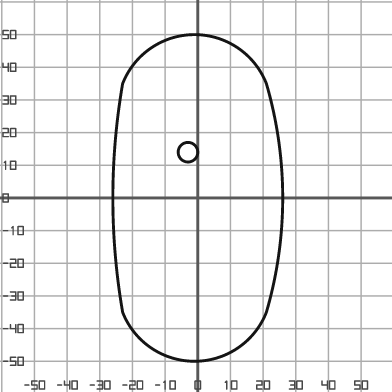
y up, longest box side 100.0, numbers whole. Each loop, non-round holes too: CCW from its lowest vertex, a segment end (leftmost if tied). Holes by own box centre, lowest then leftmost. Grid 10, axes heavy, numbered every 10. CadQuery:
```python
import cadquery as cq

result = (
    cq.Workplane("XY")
    .moveTo(-23.0, -35.0)
    .threePointArc((-1.0, -50.0), (21.0, -35.0))
    .threePointArc((26.0, 0.0), (21.0, 35.0))
    .threePointArc((-1.0, 50.0), (-23.0, 35.0))
    .threePointArc((-26.0, 0.0), (-23.0, -35.0))
    .close()
    .moveTo(-3.0, 14.0)
    .circle(3.0)
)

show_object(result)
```